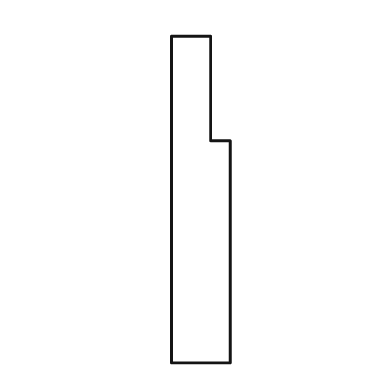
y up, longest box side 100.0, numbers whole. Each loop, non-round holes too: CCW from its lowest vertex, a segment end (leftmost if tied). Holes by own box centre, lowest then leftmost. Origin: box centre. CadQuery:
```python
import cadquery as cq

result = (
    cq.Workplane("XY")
    .moveTo(-9.0, -50.0)
    .lineTo(9.0, -50.0)
    .lineTo(9.0, 18.0)
    .lineTo(3.0, 18.0)
    .lineTo(3.0, 50.0)
    .lineTo(-9.0, 50.0)
    .close()
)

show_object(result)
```